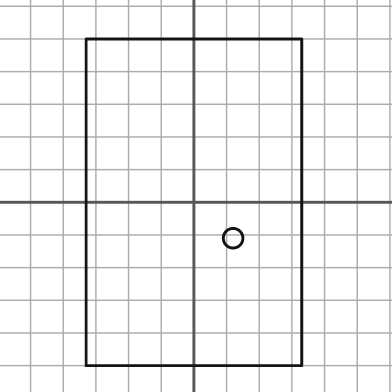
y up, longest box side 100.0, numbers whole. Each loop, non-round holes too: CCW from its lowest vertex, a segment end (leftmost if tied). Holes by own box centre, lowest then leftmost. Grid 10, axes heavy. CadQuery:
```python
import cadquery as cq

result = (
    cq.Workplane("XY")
    .moveTo(-33.0, -50.0)
    .lineTo(33.0, -50.0)
    .lineTo(33.0, 50.0)
    .lineTo(-33.0, 50.0)
    .close()
    .moveTo(12.0, -11.0)
    .circle(3.0)
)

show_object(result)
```